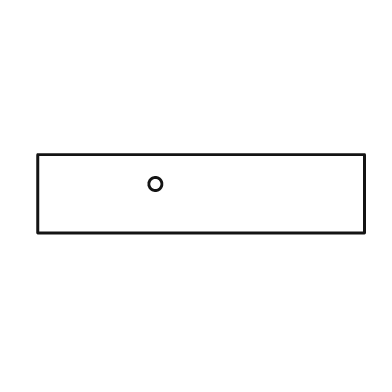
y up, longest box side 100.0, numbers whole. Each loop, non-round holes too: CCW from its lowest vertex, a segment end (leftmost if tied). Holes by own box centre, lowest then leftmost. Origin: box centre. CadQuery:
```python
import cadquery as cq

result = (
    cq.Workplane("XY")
    .moveTo(-50.0, -12.0)
    .lineTo(50.0, -12.0)
    .lineTo(50.0, 12.0)
    .lineTo(-50.0, 12.0)
    .close()
    .moveTo(-14.0, 3.0)
    .circle(2.0)
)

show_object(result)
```